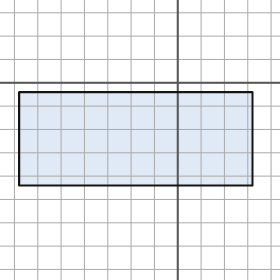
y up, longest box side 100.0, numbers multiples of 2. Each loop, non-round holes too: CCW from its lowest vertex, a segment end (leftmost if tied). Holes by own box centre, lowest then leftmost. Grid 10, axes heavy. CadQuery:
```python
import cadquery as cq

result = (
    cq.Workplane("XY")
    .moveTo(-68.0, -44.0)
    .lineTo(32.0, -44.0)
    .lineTo(32.0, -4.0)
    .lineTo(-68.0, -4.0)
    .close()
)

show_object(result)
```